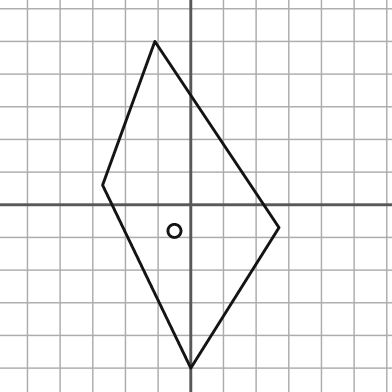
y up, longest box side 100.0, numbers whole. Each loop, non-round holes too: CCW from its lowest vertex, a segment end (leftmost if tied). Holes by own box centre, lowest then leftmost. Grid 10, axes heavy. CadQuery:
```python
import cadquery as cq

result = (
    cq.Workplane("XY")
    .moveTo(0.0, -50.0)
    .lineTo(27.0, -7.0)
    .lineTo(-11.0, 50.0)
    .lineTo(-27.0, 6.0)
    .close()
    .moveTo(-5.0, -8.0)
    .circle(2.0)
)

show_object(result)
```